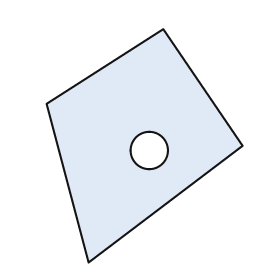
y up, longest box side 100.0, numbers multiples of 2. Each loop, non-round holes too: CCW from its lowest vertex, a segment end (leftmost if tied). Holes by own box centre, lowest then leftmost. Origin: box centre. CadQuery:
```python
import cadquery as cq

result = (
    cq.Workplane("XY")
    .moveTo(-24.0, -50.0)
    .lineTo(42.0, 0.0)
    .lineTo(8.0, 50.0)
    .lineTo(-42.0, 18.0)
    .close()
    .moveTo(2.0, -2.0)
    .circle(8.0)
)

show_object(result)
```